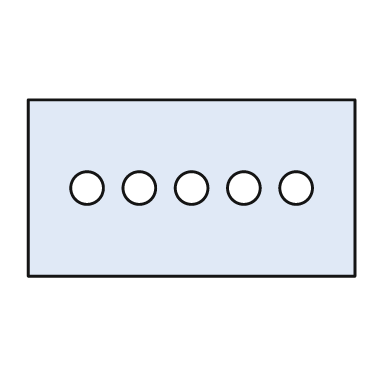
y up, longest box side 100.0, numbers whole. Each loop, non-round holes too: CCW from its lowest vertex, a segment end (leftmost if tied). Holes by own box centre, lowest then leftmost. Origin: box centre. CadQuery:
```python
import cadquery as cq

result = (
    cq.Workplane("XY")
    .moveTo(-50.0, -27.0)
    .lineTo(50.0, -27.0)
    .lineTo(50.0, 27.0)
    .lineTo(-50.0, 27.0)
    .close()
    .moveTo(-32.0, 0.0)
    .circle(5.0)
    .moveTo(-16.0, 0.0)
    .circle(5.0)
    .moveTo(0.0, 0.0)
    .circle(5.0)
    .moveTo(16.0, 0.0)
    .circle(5.0)
    .moveTo(32.0, 0.0)
    .circle(5.0)
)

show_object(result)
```